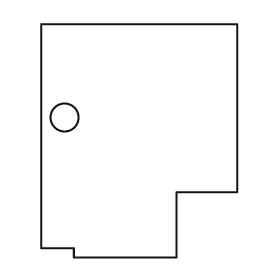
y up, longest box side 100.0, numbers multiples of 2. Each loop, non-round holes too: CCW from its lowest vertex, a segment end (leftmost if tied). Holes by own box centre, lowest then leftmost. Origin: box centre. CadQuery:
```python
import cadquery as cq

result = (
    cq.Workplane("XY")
    .moveTo(-28.0, -50.0)
    .lineTo(16.0, -50.0)
    .lineTo(16.0, -22.0)
    .lineTo(42.0, -22.0)
    .lineTo(42.0, 50.0)
    .lineTo(-42.0, 50.0)
    .lineTo(-42.0, -46.0)
    .lineTo(-28.0, -46.0)
    .close()
    .moveTo(-32.0, 10.0)
    .circle(6.0)
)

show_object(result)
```